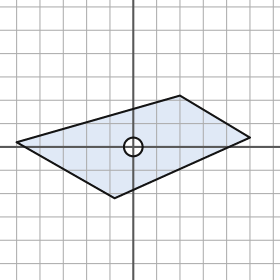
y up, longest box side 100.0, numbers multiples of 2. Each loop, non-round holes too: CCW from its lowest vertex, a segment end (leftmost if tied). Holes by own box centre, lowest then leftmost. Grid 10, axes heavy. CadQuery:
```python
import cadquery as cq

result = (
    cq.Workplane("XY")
    .moveTo(-8.0, -22.0)
    .lineTo(50.0, 4.0)
    .lineTo(20.0, 22.0)
    .lineTo(-50.0, 2.0)
    .close()
    .moveTo(0.0, 0.0)
    .circle(4.0)
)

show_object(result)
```